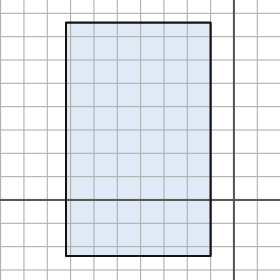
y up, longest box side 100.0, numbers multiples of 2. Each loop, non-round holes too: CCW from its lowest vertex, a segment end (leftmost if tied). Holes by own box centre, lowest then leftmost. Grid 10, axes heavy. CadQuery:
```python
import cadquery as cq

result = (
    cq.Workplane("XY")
    .moveTo(-72.0, -24.0)
    .lineTo(-10.0, -24.0)
    .lineTo(-10.0, 76.0)
    .lineTo(-72.0, 76.0)
    .close()
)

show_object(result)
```